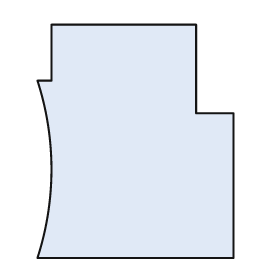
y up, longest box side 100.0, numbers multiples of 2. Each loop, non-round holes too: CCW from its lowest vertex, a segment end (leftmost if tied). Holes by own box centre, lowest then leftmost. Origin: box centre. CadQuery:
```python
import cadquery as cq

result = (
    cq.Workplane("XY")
    .moveTo(-42.0, -50.0)
    .lineTo(42.0, -50.0)
    .lineTo(42.0, 12.0)
    .lineTo(26.0, 12.0)
    .lineTo(26.0, 50.0)
    .lineTo(-36.0, 50.0)
    .lineTo(-36.0, 26.0)
    .lineTo(-42.0, 26.0)
    .threePointArc((-36.0, -12.0), (-42.0, -50.0))
    .close()
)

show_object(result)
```